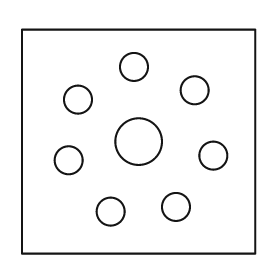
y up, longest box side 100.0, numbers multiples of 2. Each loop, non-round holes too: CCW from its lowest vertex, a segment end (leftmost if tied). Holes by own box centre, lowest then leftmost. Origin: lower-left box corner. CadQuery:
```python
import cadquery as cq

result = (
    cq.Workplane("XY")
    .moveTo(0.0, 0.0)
    .lineTo(100.0, 0.0)
    .lineTo(100.0, 96.0)
    .lineTo(0.0, 96.0)
    .close()
    .moveTo(38.0, 18.0)
    .circle(6.0)
    .moveTo(66.0, 20.0)
    .circle(6.0)
    .moveTo(20.0, 40.0)
    .circle(6.0)
    .moveTo(82.0, 42.0)
    .circle(6.0)
    .moveTo(50.0, 48.0)
    .circle(10.0)
    .moveTo(24.0, 66.0)
    .circle(6.0)
    .moveTo(74.0, 70.0)
    .circle(6.0)
    .moveTo(48.0, 80.0)
    .circle(6.0)
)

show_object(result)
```